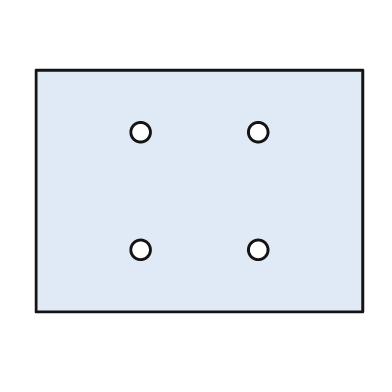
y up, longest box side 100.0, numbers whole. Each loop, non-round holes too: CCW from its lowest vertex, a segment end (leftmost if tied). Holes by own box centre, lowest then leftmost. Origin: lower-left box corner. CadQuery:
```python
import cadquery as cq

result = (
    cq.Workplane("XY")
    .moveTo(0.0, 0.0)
    .lineTo(100.0, 0.0)
    .lineTo(100.0, 74.0)
    .lineTo(0.0, 74.0)
    .close()
    .moveTo(32.0, 19.0)
    .circle(3.0)
    .moveTo(68.0, 19.0)
    .circle(3.0)
    .moveTo(32.0, 55.0)
    .circle(3.0)
    .moveTo(68.0, 55.0)
    .circle(3.0)
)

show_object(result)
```